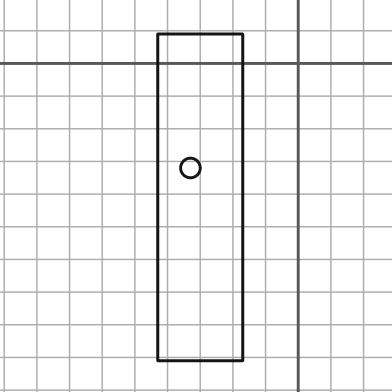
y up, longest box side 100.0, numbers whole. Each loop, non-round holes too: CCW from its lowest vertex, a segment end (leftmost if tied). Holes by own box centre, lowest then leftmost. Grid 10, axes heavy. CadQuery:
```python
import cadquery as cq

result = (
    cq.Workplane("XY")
    .moveTo(-43.0, -91.0)
    .lineTo(-17.0, -91.0)
    .lineTo(-17.0, 9.0)
    .lineTo(-43.0, 9.0)
    .close()
    .moveTo(-33.0, -32.0)
    .circle(3.0)
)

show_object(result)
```